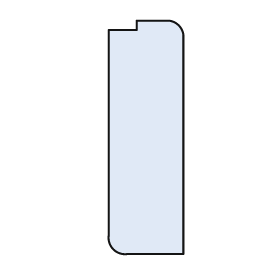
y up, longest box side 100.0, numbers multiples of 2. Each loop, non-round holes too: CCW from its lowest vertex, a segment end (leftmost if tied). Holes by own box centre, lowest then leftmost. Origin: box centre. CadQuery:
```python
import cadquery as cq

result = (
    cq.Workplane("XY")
    .moveTo(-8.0, -50.0)
    .lineTo(16.0, -50.0)
    .lineTo(16.0, 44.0)
    .threePointArc((14.0, 48.0), (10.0, 50.0))
    .lineTo(-4.0, 50.0)
    .lineTo(-4.0, 46.0)
    .lineTo(-16.0, 46.0)
    .lineTo(-16.0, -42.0)
    .threePointArc((-14.0, -48.0), (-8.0, -50.0))
    .close()
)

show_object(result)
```